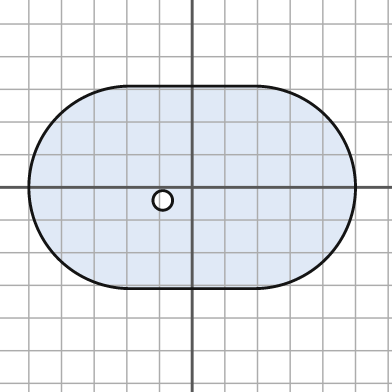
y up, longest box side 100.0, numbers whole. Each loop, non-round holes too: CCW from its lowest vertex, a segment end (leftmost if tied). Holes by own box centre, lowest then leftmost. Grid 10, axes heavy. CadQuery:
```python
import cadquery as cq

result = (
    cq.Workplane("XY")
    .moveTo(-19.0, -31.0)
    .lineTo(19.0, -31.0)
    .threePointArc((50.0, 0.0), (19.0, 31.0))
    .lineTo(-19.0, 31.0)
    .threePointArc((-50.0, 0.0), (-19.0, -31.0))
    .close()
    .moveTo(-9.0, -4.0)
    .circle(3.0)
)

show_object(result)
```